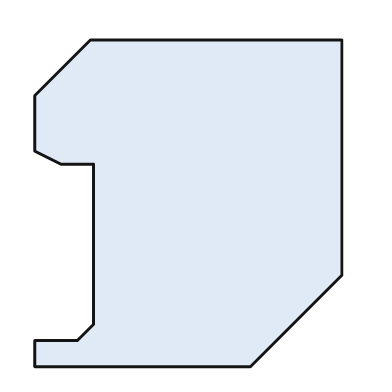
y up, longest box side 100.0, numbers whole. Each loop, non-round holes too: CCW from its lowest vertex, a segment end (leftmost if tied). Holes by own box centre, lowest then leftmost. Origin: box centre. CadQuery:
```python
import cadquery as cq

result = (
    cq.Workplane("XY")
    .moveTo(-47.0, -50.0)
    .lineTo(19.0, -50.0)
    .lineTo(47.0, -22.0)
    .lineTo(47.0, 50.0)
    .lineTo(-30.0, 50.0)
    .lineTo(-47.0, 33.0)
    .lineTo(-47.0, 16.0)
    .lineTo(-39.0, 12.0)
    .lineTo(-29.0, 12.0)
    .lineTo(-29.0, -37.0)
    .lineTo(-34.0, -42.0)
    .lineTo(-47.0, -42.0)
    .close()
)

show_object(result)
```